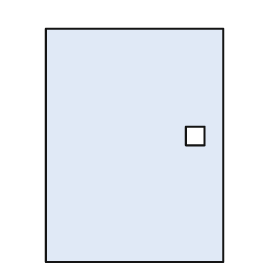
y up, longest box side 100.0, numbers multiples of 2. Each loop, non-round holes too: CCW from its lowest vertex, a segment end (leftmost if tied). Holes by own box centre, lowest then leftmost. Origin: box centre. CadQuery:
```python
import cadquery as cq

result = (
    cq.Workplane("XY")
    .moveTo(-38.0, -50.0)
    .lineTo(38.0, -50.0)
    .lineTo(38.0, 50.0)
    .lineTo(-38.0, 50.0)
    .close()
    .moveTo(22.0, 0.0)
    .lineTo(30.0, 0.0)
    .lineTo(30.0, 8.0)
    .lineTo(22.0, 8.0)
    .close()
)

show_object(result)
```